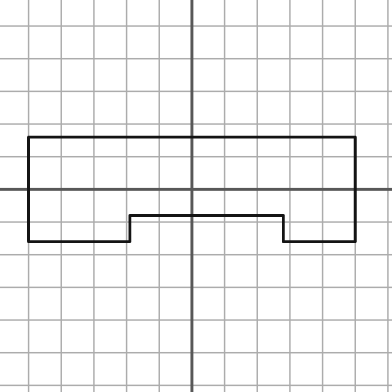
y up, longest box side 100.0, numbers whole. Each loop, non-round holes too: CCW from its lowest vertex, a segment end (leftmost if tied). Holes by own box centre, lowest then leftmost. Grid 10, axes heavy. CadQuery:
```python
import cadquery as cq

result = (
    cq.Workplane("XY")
    .moveTo(-50.0, -16.0)
    .lineTo(-19.0, -16.0)
    .lineTo(-19.0, -8.0)
    .lineTo(28.0, -8.0)
    .lineTo(28.0, -16.0)
    .lineTo(50.0, -16.0)
    .lineTo(50.0, 16.0)
    .lineTo(-50.0, 16.0)
    .close()
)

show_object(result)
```